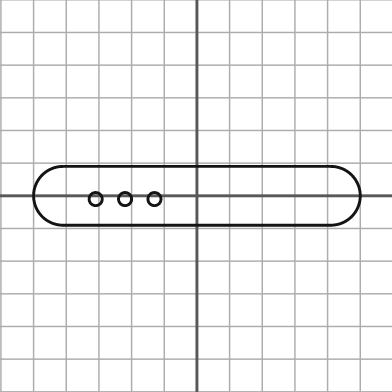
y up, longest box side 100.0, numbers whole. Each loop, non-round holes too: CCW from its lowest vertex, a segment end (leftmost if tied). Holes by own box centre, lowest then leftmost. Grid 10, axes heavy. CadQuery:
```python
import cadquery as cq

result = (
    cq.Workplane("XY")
    .moveTo(-41.0, -9.0)
    .lineTo(41.0, -9.0)
    .threePointArc((50.0, 0.0), (41.0, 9.0))
    .lineTo(-41.0, 9.0)
    .threePointArc((-50.0, 0.0), (-41.0, -9.0))
    .close()
    .moveTo(-31.0, -1.0)
    .circle(2.0)
    .moveTo(-22.0, -1.0)
    .circle(2.0)
    .moveTo(-13.0, -1.0)
    .circle(2.0)
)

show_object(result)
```